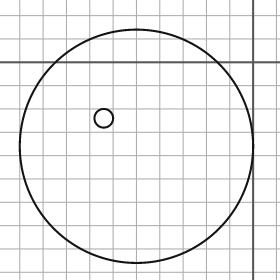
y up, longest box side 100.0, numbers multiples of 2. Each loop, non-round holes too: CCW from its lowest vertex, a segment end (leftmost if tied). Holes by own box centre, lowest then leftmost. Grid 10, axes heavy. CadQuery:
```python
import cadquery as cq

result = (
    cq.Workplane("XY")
    .moveTo(-50.0, -36.0)
    .circle(50.0)
    .moveTo(-64.0, -24.0)
    .circle(4.0)
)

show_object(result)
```